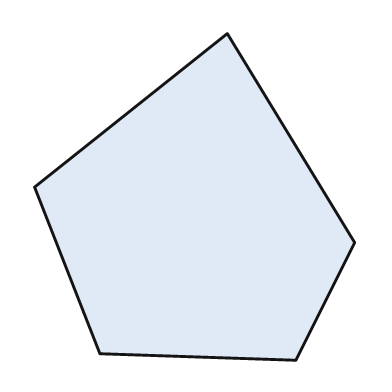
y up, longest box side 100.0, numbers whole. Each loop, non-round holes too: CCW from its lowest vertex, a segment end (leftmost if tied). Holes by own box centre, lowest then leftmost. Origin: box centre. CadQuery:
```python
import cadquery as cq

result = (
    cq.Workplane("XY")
    .moveTo(31.0, -50.0)
    .lineTo(49.0, -14.0)
    .lineTo(10.0, 50.0)
    .lineTo(-49.0, 3.0)
    .lineTo(-29.0, -48.0)
    .close()
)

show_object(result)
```